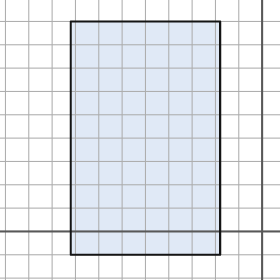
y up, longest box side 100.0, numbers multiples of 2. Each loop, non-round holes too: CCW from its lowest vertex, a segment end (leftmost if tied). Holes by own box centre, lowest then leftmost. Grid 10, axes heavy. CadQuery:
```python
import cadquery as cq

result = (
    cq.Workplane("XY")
    .moveTo(-82.0, -10.0)
    .lineTo(-18.0, -10.0)
    .lineTo(-18.0, 90.0)
    .lineTo(-82.0, 90.0)
    .close()
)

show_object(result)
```